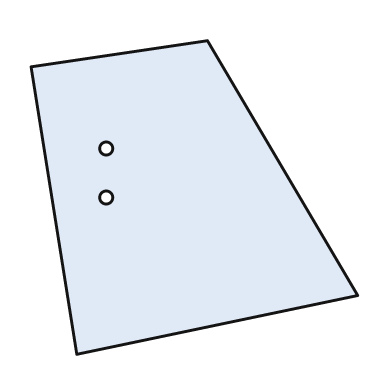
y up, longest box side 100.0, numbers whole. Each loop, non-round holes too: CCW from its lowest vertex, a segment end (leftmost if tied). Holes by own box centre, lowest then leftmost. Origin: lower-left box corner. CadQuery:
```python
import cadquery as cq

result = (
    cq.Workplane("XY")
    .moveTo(14.0, 0.0)
    .lineTo(100.0, 18.0)
    .lineTo(54.0, 96.0)
    .lineTo(0.0, 88.0)
    .close()
    .moveTo(23.0, 48.0)
    .circle(2.0)
    .moveTo(23.0, 63.0)
    .circle(2.0)
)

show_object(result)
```